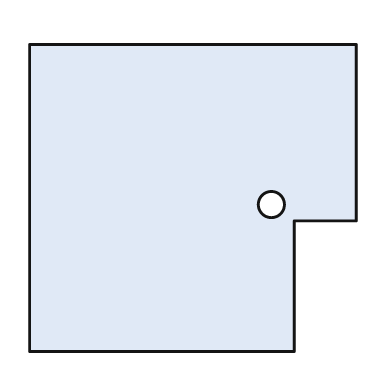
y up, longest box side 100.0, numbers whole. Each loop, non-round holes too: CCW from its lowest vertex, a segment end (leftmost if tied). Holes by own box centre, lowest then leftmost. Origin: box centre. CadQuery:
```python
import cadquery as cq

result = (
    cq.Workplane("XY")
    .moveTo(-50.0, -47.0)
    .lineTo(31.0, -47.0)
    .lineTo(31.0, -7.0)
    .lineTo(50.0, -7.0)
    .lineTo(50.0, 47.0)
    .lineTo(-50.0, 47.0)
    .close()
    .moveTo(24.0, -2.0)
    .circle(4.0)
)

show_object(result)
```